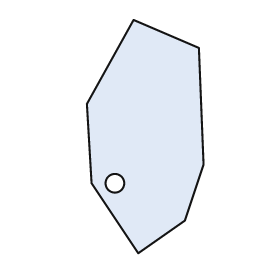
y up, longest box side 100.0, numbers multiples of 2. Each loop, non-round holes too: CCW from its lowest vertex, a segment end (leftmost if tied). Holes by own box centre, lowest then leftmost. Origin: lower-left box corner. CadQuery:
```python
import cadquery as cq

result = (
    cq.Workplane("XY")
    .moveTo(22.0, 0.0)
    .lineTo(42.0, 14.0)
    .lineTo(50.0, 38.0)
    .lineTo(48.0, 88.0)
    .lineTo(20.0, 100.0)
    .lineTo(0.0, 64.0)
    .lineTo(2.0, 30.0)
    .close()
    .moveTo(12.0, 30.0)
    .circle(4.0)
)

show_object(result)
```